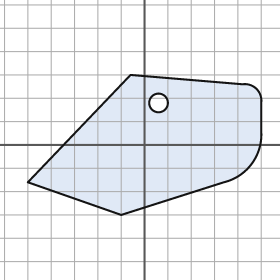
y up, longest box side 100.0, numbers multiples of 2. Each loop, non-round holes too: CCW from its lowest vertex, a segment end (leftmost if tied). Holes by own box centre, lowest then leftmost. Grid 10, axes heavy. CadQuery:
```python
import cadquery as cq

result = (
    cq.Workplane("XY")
    .moveTo(-10.0, -30.0)
    .lineTo(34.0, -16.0)
    .threePointArc((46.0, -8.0), (50.0, 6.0))
    .lineTo(50.0, 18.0)
    .threePointArc((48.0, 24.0), (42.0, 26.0))
    .lineTo(-6.0, 30.0)
    .lineTo(-50.0, -16.0)
    .close()
    .moveTo(6.0, 18.0)
    .circle(4.0)
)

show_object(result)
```